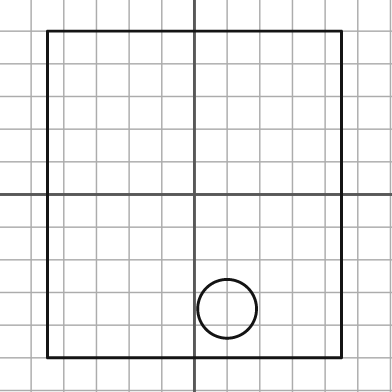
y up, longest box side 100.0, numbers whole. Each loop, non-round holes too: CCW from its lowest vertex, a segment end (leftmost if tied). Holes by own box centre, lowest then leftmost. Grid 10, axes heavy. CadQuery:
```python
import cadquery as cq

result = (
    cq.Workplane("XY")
    .moveTo(-45.0, -50.0)
    .lineTo(45.0, -50.0)
    .lineTo(45.0, 50.0)
    .lineTo(-45.0, 50.0)
    .close()
    .moveTo(10.0, -35.0)
    .circle(9.0)
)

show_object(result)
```